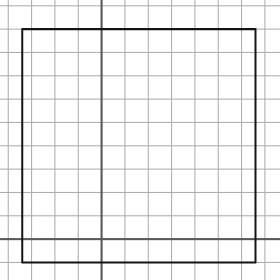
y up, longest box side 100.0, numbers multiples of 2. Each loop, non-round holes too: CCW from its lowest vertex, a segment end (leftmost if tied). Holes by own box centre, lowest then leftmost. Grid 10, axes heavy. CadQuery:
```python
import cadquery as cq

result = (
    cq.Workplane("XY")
    .moveTo(-34.0, -10.0)
    .lineTo(66.0, -10.0)
    .lineTo(66.0, 90.0)
    .lineTo(-34.0, 90.0)
    .close()
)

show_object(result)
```